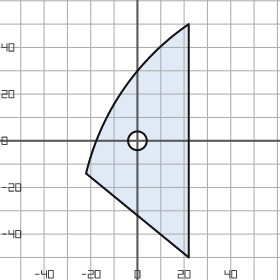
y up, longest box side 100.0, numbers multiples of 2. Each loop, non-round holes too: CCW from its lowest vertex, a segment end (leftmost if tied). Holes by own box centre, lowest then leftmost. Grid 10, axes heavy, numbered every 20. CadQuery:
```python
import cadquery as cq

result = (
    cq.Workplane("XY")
    .moveTo(22.0, -50.0)
    .lineTo(22.0, 50.0)
    .threePointArc((-6.0, 22.0), (-22.0, -14.0))
    .close()
    .moveTo(0.0, 0.0)
    .circle(4.0)
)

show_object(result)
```